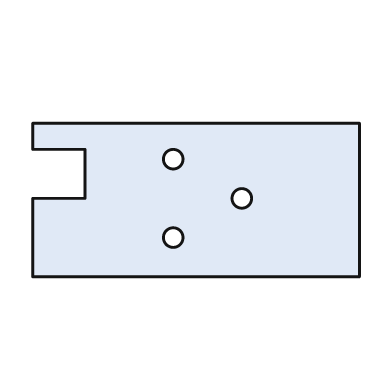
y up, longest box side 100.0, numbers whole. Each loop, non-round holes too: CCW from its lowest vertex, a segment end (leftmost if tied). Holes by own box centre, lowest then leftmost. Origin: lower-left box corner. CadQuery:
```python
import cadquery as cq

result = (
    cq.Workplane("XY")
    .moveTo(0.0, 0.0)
    .lineTo(100.0, 0.0)
    .lineTo(100.0, 47.0)
    .lineTo(0.0, 47.0)
    .lineTo(0.0, 39.0)
    .lineTo(16.0, 39.0)
    .lineTo(16.0, 24.0)
    .lineTo(0.0, 24.0)
    .close()
    .moveTo(43.0, 12.0)
    .circle(3.0)
    .moveTo(64.0, 24.0)
    .circle(3.0)
    .moveTo(43.0, 36.0)
    .circle(3.0)
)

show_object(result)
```